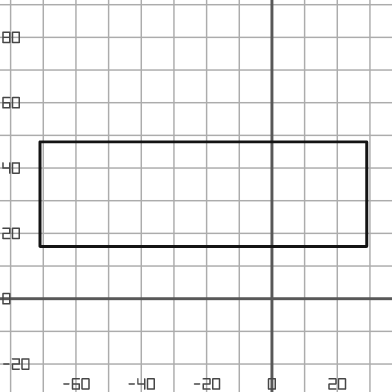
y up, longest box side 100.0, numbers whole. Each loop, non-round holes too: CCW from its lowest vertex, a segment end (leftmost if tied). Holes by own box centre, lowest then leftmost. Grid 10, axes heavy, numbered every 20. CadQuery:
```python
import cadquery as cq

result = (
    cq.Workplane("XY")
    .moveTo(-71.0, 16.0)
    .lineTo(29.0, 16.0)
    .lineTo(29.0, 48.0)
    .lineTo(-71.0, 48.0)
    .close()
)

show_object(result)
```